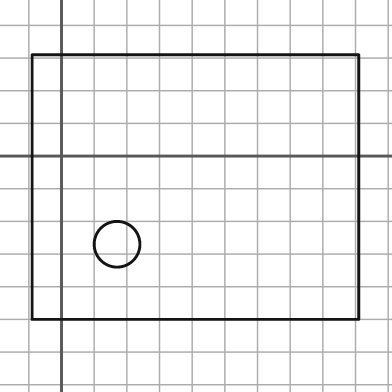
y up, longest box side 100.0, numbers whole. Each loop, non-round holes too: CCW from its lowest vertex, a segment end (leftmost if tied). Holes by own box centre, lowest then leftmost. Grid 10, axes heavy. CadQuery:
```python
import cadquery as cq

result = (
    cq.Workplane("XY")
    .moveTo(-9.0, -50.0)
    .lineTo(91.0, -50.0)
    .lineTo(91.0, 31.0)
    .lineTo(-9.0, 31.0)
    .close()
    .moveTo(17.0, -27.0)
    .circle(7.0)
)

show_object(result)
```